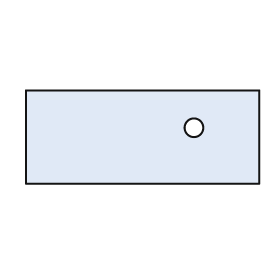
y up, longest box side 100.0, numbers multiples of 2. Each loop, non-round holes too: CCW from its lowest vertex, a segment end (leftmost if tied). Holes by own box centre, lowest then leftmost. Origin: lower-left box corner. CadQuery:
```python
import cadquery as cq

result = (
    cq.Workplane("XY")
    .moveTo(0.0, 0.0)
    .lineTo(100.0, 0.0)
    .lineTo(100.0, 40.0)
    .lineTo(0.0, 40.0)
    .close()
    .moveTo(72.0, 24.0)
    .circle(4.0)
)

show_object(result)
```